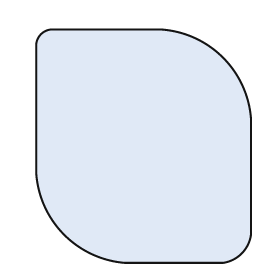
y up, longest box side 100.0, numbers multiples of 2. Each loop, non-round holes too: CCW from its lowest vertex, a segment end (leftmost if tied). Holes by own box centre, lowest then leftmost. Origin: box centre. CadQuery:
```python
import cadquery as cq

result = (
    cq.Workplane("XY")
    .moveTo(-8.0, -50.0)
    .lineTo(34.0, -50.0)
    .threePointArc((42.0, -46.0), (46.0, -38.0))
    .lineTo(46.0, 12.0)
    .threePointArc((34.0, 38.0), (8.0, 50.0))
    .lineTo(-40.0, 50.0)
    .threePointArc((-44.0, 48.0), (-46.0, 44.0))
    .lineTo(-46.0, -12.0)
    .threePointArc((-34.0, -38.0), (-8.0, -50.0))
    .close()
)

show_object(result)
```